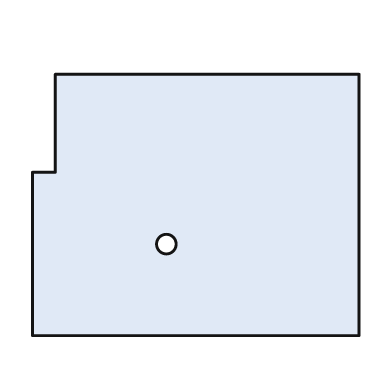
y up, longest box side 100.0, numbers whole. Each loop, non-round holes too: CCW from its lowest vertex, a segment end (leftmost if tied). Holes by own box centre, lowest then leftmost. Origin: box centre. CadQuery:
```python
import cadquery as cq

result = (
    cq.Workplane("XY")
    .moveTo(-50.0, -40.0)
    .lineTo(50.0, -40.0)
    .lineTo(50.0, 40.0)
    .lineTo(-43.0, 40.0)
    .lineTo(-43.0, 10.0)
    .lineTo(-50.0, 10.0)
    .close()
    .moveTo(-9.0, -12.0)
    .circle(3.0)
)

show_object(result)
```